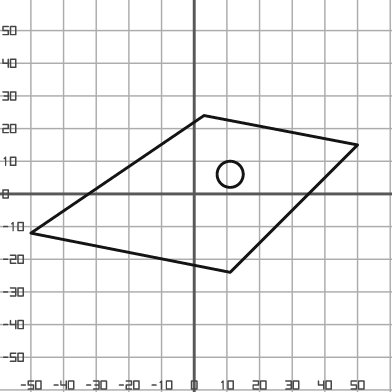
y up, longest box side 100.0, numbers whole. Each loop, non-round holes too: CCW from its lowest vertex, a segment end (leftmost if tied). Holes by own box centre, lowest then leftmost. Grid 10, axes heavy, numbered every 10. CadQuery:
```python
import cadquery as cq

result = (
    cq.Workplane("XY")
    .moveTo(11.0, -24.0)
    .lineTo(50.0, 15.0)
    .lineTo(3.0, 24.0)
    .lineTo(-50.0, -12.0)
    .close()
    .moveTo(11.0, 6.0)
    .circle(4.0)
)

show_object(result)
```